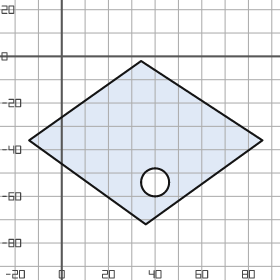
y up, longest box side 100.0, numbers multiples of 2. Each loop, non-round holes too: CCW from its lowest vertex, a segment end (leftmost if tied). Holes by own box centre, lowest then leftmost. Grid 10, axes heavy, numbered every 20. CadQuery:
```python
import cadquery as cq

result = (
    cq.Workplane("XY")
    .moveTo(36.0, -72.0)
    .lineTo(86.0, -36.0)
    .lineTo(34.0, -2.0)
    .lineTo(-14.0, -36.0)
    .close()
    .moveTo(40.0, -54.0)
    .circle(6.0)
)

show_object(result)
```